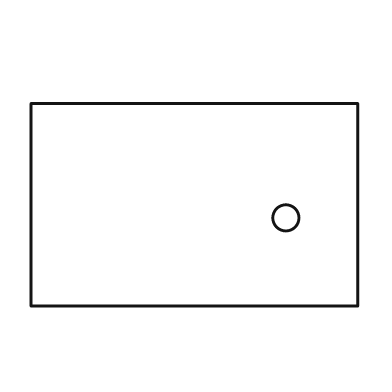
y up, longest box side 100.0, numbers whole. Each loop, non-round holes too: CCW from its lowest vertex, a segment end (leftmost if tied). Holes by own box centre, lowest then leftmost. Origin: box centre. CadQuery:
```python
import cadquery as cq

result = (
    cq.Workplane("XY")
    .moveTo(-50.0, -31.0)
    .lineTo(50.0, -31.0)
    .lineTo(50.0, 31.0)
    .lineTo(-50.0, 31.0)
    .close()
    .moveTo(28.0, -4.0)
    .circle(4.0)
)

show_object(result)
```